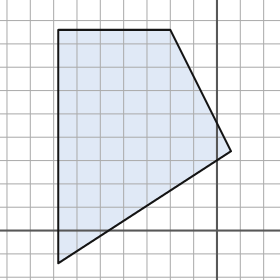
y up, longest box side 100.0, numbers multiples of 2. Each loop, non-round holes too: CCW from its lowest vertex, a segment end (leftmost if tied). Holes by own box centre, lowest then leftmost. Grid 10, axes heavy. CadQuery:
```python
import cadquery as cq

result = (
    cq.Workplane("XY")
    .moveTo(-68.0, -14.0)
    .lineTo(6.0, 34.0)
    .lineTo(-20.0, 86.0)
    .lineTo(-68.0, 86.0)
    .close()
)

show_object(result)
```